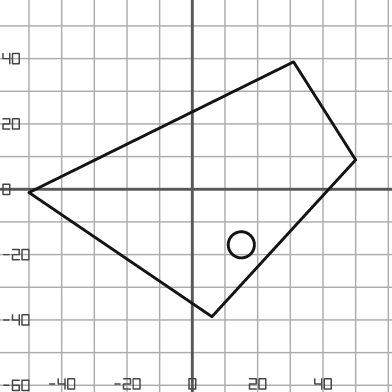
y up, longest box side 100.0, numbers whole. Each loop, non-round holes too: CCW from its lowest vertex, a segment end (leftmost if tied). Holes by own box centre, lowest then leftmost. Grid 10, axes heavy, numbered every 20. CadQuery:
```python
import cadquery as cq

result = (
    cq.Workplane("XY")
    .moveTo(6.0, -39.0)
    .lineTo(50.0, 9.0)
    .lineTo(31.0, 39.0)
    .lineTo(-50.0, -1.0)
    .close()
    .moveTo(15.0, -17.0)
    .circle(4.0)
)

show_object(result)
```